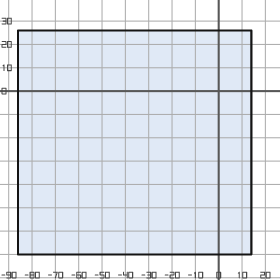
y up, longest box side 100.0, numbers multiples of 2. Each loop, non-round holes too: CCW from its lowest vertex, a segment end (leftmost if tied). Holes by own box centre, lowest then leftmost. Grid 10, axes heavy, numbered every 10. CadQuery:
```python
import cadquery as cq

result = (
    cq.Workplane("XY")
    .moveTo(-86.0, -70.0)
    .lineTo(14.0, -70.0)
    .lineTo(14.0, 26.0)
    .lineTo(-86.0, 26.0)
    .close()
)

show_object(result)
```